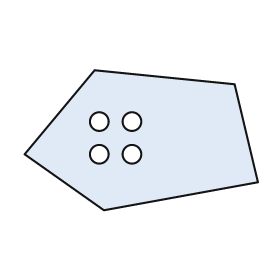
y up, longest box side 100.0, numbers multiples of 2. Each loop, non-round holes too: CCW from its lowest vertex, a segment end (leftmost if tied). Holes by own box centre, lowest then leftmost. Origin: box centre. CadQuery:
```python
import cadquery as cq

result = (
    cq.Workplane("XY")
    .moveTo(-16.0, -30.0)
    .lineTo(50.0, -18.0)
    .lineTo(40.0, 24.0)
    .lineTo(-20.0, 30.0)
    .lineTo(-50.0, -6.0)
    .close()
    .moveTo(-18.0, -6.0)
    .circle(4.0)
    .moveTo(-4.0, -6.0)
    .circle(4.0)
    .moveTo(-18.0, 8.0)
    .circle(4.0)
    .moveTo(-4.0, 8.0)
    .circle(4.0)
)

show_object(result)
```